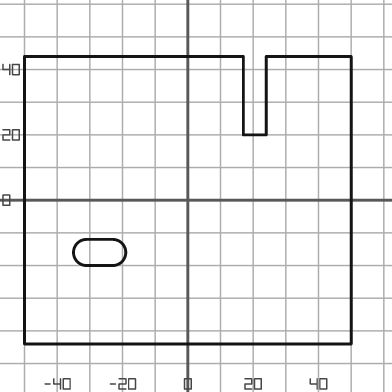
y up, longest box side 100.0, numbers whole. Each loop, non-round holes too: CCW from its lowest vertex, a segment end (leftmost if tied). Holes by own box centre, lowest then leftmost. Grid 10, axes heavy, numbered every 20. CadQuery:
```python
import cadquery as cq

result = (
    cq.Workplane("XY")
    .moveTo(-50.0, -44.0)
    .lineTo(50.0, -44.0)
    .lineTo(50.0, 44.0)
    .lineTo(24.0, 44.0)
    .lineTo(24.0, 20.0)
    .lineTo(17.0, 20.0)
    .lineTo(17.0, 44.0)
    .lineTo(-50.0, 44.0)
    .close()
    .moveTo(-31.0, -20.0)
    .lineTo(-23.0, -20.0)
    .threePointArc((-19.0, -16.0), (-23.0, -12.0))
    .lineTo(-31.0, -12.0)
    .threePointArc((-35.0, -16.0), (-31.0, -20.0))
    .close()
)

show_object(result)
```